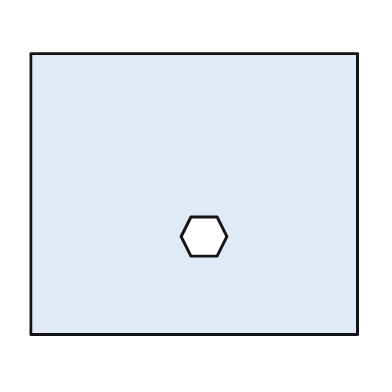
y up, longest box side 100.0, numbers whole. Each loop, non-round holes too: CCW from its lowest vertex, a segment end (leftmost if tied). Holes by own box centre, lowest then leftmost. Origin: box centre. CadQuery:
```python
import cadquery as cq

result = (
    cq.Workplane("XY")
    .moveTo(-50.0, -43.0)
    .lineTo(50.0, -43.0)
    .lineTo(50.0, 43.0)
    .lineTo(-50.0, 43.0)
    .close()
    .moveTo(-1.0, -19.0)
    .lineTo(7.0, -19.0)
    .lineTo(10.0, -13.0)
    .lineTo(7.0, -7.0)
    .lineTo(-1.0, -7.0)
    .lineTo(-4.0, -13.0)
    .close()
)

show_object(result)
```